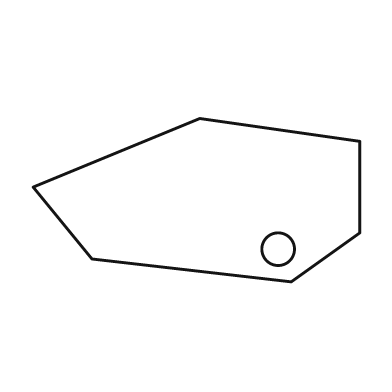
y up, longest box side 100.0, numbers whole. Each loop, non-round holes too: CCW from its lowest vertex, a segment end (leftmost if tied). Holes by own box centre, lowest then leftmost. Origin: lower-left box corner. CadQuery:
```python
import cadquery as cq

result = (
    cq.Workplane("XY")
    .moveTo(79.0, 0.0)
    .lineTo(100.0, 15.0)
    .lineTo(100.0, 43.0)
    .lineTo(51.0, 50.0)
    .lineTo(0.0, 29.0)
    .lineTo(18.0, 7.0)
    .close()
    .moveTo(75.0, 10.0)
    .circle(5.0)
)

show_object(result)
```